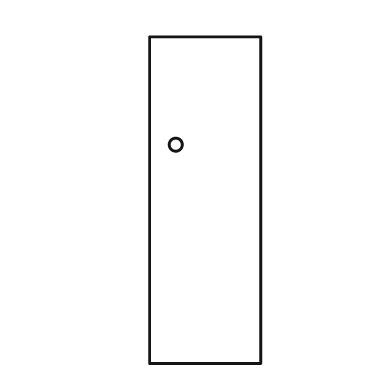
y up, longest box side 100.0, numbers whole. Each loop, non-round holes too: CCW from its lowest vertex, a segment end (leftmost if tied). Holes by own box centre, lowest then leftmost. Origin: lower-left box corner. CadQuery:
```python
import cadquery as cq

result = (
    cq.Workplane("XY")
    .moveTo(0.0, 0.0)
    .lineTo(34.0, 0.0)
    .lineTo(34.0, 100.0)
    .lineTo(0.0, 100.0)
    .close()
    .moveTo(8.0, 67.0)
    .circle(2.0)
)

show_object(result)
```